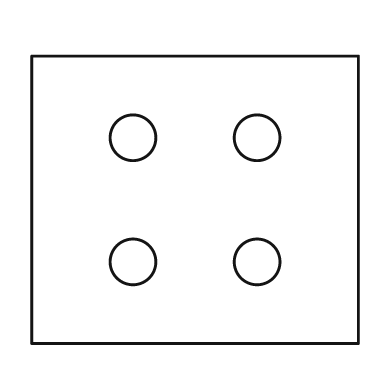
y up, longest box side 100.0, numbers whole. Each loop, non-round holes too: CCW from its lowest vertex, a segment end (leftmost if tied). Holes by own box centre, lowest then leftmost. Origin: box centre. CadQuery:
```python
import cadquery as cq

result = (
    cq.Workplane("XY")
    .moveTo(-50.0, -44.0)
    .lineTo(50.0, -44.0)
    .lineTo(50.0, 44.0)
    .lineTo(-50.0, 44.0)
    .close()
    .moveTo(-19.0, -19.0)
    .circle(7.0)
    .moveTo(19.0, -19.0)
    .circle(7.0)
    .moveTo(-19.0, 19.0)
    .circle(7.0)
    .moveTo(19.0, 19.0)
    .circle(7.0)
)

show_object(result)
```